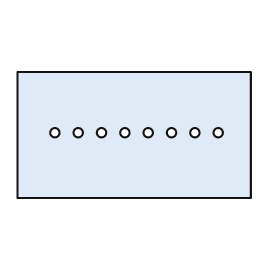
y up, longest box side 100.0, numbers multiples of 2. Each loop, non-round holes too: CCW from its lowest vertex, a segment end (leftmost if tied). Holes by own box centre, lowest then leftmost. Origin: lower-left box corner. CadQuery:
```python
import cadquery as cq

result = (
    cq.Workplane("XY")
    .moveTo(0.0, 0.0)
    .lineTo(100.0, 0.0)
    .lineTo(100.0, 54.0)
    .lineTo(0.0, 54.0)
    .close()
    .moveTo(16.0, 28.0)
    .circle(2.0)
    .moveTo(26.0, 28.0)
    .circle(2.0)
    .moveTo(36.0, 28.0)
    .circle(2.0)
    .moveTo(46.0, 28.0)
    .circle(2.0)
    .moveTo(56.0, 28.0)
    .circle(2.0)
    .moveTo(66.0, 28.0)
    .circle(2.0)
    .moveTo(76.0, 28.0)
    .circle(2.0)
    .moveTo(86.0, 28.0)
    .circle(2.0)
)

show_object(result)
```